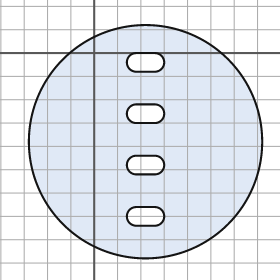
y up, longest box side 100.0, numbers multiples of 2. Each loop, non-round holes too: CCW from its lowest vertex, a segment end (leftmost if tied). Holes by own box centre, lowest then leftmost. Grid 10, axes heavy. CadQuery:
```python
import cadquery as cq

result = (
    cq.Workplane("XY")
    .moveTo(22.0, -38.0)
    .circle(50.0)
    .moveTo(18.0, -74.0)
    .lineTo(26.0, -74.0)
    .threePointArc((30.0, -70.0), (26.0, -66.0))
    .lineTo(18.0, -66.0)
    .threePointArc((14.0, -70.0), (18.0, -74.0))
    .close()
    .moveTo(18.0, -52.0)
    .lineTo(26.0, -52.0)
    .threePointArc((30.0, -48.0), (26.0, -44.0))
    .lineTo(18.0, -44.0)
    .threePointArc((14.0, -48.0), (18.0, -52.0))
    .close()
    .moveTo(18.0, -30.0)
    .lineTo(26.0, -30.0)
    .threePointArc((30.0, -26.0), (26.0, -22.0))
    .lineTo(18.0, -22.0)
    .threePointArc((14.0, -26.0), (18.0, -30.0))
    .close()
    .moveTo(18.0, -8.0)
    .lineTo(26.0, -8.0)
    .threePointArc((30.0, -4.0), (26.0, 0.0))
    .lineTo(18.0, 0.0)
    .threePointArc((14.0, -4.0), (18.0, -8.0))
    .close()
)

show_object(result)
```